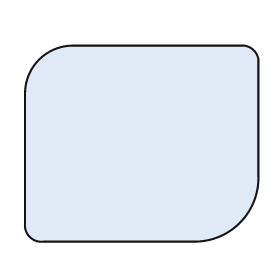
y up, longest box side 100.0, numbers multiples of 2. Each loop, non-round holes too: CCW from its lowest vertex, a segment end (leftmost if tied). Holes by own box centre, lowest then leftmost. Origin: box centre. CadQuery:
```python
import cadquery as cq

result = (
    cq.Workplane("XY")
    .moveTo(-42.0, -42.0)
    .lineTo(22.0, -42.0)
    .threePointArc((42.0, -34.0), (50.0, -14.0))
    .lineTo(50.0, 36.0)
    .threePointArc((48.0, 40.0), (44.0, 42.0))
    .lineTo(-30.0, 42.0)
    .threePointArc((-44.0, 36.0), (-50.0, 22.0))
    .lineTo(-50.0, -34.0)
    .threePointArc((-48.0, -40.0), (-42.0, -42.0))
    .close()
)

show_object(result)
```